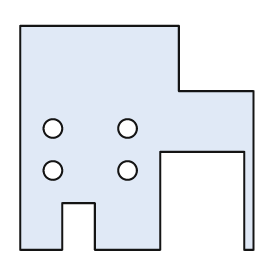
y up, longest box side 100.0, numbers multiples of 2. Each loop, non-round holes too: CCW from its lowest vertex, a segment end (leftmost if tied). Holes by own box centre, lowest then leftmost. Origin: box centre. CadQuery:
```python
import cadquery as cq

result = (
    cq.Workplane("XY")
    .moveTo(-50.0, -48.0)
    .lineTo(-32.0, -48.0)
    .lineTo(-32.0, -28.0)
    .lineTo(-18.0, -28.0)
    .lineTo(-18.0, -48.0)
    .lineTo(10.0, -48.0)
    .lineTo(10.0, -6.0)
    .lineTo(46.0, -6.0)
    .lineTo(46.0, -48.0)
    .lineTo(50.0, -48.0)
    .lineTo(50.0, 20.0)
    .lineTo(18.0, 20.0)
    .lineTo(18.0, 48.0)
    .lineTo(-50.0, 48.0)
    .close()
    .moveTo(-36.0, -14.0)
    .circle(4.0)
    .moveTo(-4.0, -14.0)
    .circle(4.0)
    .moveTo(-36.0, 4.0)
    .circle(4.0)
    .moveTo(-4.0, 4.0)
    .circle(4.0)
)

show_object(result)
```